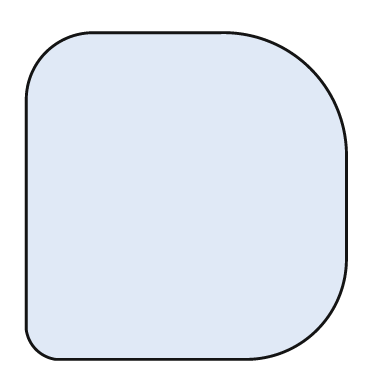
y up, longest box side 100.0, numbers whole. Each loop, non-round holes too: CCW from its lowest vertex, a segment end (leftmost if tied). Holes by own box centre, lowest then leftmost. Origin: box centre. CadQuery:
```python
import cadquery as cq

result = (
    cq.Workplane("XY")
    .moveTo(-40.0, -50.0)
    .lineTo(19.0, -50.0)
    .threePointArc((40.0, -41.0), (49.0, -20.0))
    .lineTo(49.0, 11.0)
    .threePointArc((38.0, 39.0), (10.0, 50.0))
    .lineTo(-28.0, 50.0)
    .threePointArc((-43.0, 44.0), (-49.0, 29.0))
    .lineTo(-49.0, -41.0)
    .threePointArc((-46.0, -47.0), (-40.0, -50.0))
    .close()
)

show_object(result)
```